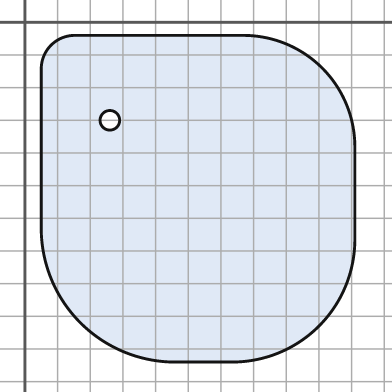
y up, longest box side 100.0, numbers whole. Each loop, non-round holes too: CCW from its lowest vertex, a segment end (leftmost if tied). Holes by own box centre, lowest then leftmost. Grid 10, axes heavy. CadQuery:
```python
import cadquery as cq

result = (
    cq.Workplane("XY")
    .moveTo(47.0, -104.0)
    .lineTo(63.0, -104.0)
    .threePointArc((90.0, -93.0), (101.0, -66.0))
    .lineTo(101.0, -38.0)
    .threePointArc((91.0, -14.0), (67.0, -4.0))
    .lineTo(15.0, -4.0)
    .threePointArc((8.0, -7.0), (5.0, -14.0))
    .lineTo(5.0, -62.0)
    .threePointArc((17.0, -92.0), (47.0, -104.0))
    .close()
    .moveTo(26.0, -30.0)
    .circle(3.0)
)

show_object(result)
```